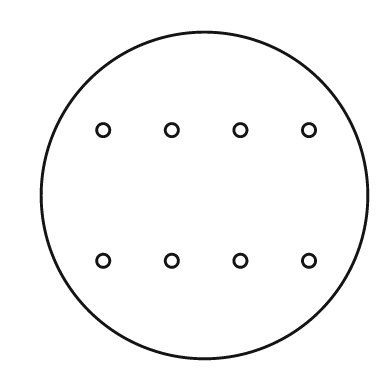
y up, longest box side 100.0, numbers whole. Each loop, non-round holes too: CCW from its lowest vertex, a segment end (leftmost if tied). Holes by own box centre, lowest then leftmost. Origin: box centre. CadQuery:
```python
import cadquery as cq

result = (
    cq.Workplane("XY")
    .moveTo(0.0, 0.0)
    .circle(50.0)
    .moveTo(-31.0, -20.0)
    .circle(2.0)
    .moveTo(-10.0, -20.0)
    .circle(2.0)
    .moveTo(11.0, -20.0)
    .circle(2.0)
    .moveTo(32.0, -20.0)
    .circle(2.0)
    .moveTo(-31.0, 20.0)
    .circle(2.0)
    .moveTo(-10.0, 20.0)
    .circle(2.0)
    .moveTo(11.0, 20.0)
    .circle(2.0)
    .moveTo(32.0, 20.0)
    .circle(2.0)
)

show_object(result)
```